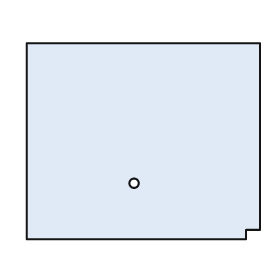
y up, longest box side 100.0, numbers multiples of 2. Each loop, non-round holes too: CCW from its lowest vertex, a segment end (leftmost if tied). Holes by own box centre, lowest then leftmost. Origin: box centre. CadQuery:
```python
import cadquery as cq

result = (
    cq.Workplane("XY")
    .moveTo(-50.0, -42.0)
    .lineTo(44.0, -42.0)
    .lineTo(44.0, -38.0)
    .lineTo(50.0, -38.0)
    .lineTo(50.0, 42.0)
    .lineTo(-50.0, 42.0)
    .close()
    .moveTo(-4.0, -18.0)
    .circle(2.0)
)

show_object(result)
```